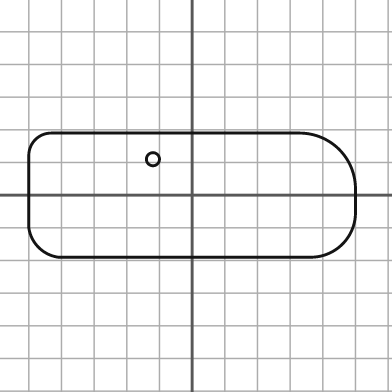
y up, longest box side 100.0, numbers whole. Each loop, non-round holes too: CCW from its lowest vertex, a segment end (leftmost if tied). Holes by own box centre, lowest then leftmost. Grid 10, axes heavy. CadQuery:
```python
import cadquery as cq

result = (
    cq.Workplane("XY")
    .moveTo(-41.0, -19.0)
    .lineTo(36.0, -19.0)
    .threePointArc((46.0, -15.0), (50.0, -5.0))
    .lineTo(50.0, 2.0)
    .threePointArc((45.0, 14.0), (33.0, 19.0))
    .lineTo(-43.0, 19.0)
    .threePointArc((-48.0, 17.0), (-50.0, 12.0))
    .lineTo(-50.0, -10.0)
    .threePointArc((-47.0, -16.0), (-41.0, -19.0))
    .close()
    .moveTo(-12.0, 11.0)
    .circle(2.0)
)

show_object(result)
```